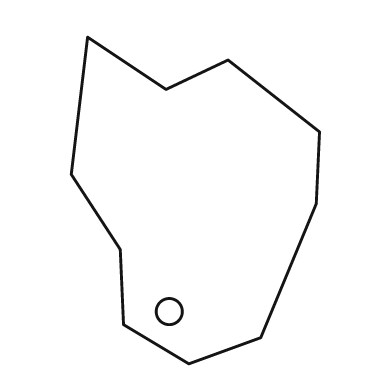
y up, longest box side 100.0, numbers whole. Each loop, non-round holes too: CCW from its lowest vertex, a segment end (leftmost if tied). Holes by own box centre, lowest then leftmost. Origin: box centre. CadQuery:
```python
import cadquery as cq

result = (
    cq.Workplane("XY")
    .moveTo(-2.0, -50.0)
    .lineTo(20.0, -42.0)
    .lineTo(37.0, -1.0)
    .lineTo(38.0, 21.0)
    .lineTo(10.0, 43.0)
    .lineTo(-9.0, 34.0)
    .lineTo(-33.0, 50.0)
    .lineTo(-38.0, 8.0)
    .lineTo(-23.0, -15.0)
    .lineTo(-22.0, -38.0)
    .close()
    .moveTo(-8.0, -34.0)
    .circle(4.0)
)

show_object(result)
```